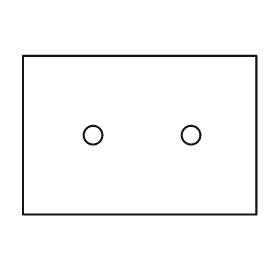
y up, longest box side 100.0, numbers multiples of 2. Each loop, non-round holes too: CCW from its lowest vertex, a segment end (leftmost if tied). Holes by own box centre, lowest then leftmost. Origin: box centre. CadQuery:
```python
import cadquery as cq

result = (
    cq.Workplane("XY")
    .moveTo(-50.0, -34.0)
    .lineTo(50.0, -34.0)
    .lineTo(50.0, 34.0)
    .lineTo(-50.0, 34.0)
    .close()
    .moveTo(-20.0, 0.0)
    .circle(4.0)
    .moveTo(22.0, 0.0)
    .circle(4.0)
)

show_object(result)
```